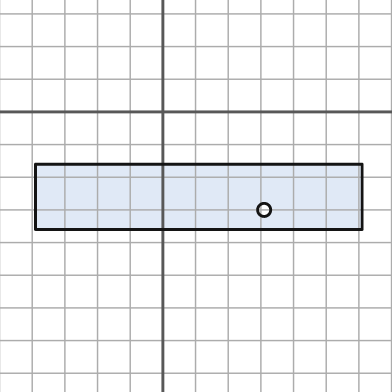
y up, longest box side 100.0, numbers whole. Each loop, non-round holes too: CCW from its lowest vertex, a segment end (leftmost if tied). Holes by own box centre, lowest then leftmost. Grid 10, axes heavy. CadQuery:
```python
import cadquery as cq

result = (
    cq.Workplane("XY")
    .moveTo(-39.0, -36.0)
    .lineTo(61.0, -36.0)
    .lineTo(61.0, -16.0)
    .lineTo(-39.0, -16.0)
    .close()
    .moveTo(31.0, -30.0)
    .circle(2.0)
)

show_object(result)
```